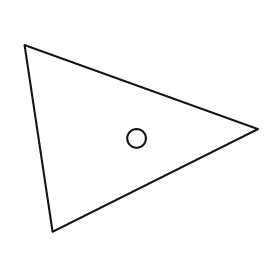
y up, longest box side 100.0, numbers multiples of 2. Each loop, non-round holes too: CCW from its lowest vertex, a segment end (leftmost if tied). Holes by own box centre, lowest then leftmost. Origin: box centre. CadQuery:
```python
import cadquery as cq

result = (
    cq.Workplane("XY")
    .moveTo(-38.0, -40.0)
    .lineTo(50.0, 4.0)
    .lineTo(-50.0, 40.0)
    .close()
    .moveTo(-2.0, 0.0)
    .circle(4.0)
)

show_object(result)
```